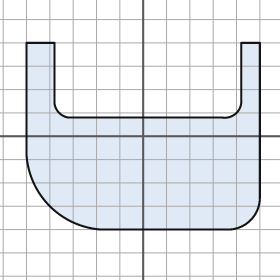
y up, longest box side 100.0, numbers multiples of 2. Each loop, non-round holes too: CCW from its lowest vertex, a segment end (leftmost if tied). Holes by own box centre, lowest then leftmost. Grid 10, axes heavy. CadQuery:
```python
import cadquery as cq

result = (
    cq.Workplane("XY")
    .moveTo(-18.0, -40.0)
    .lineTo(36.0, -40.0)
    .threePointArc((46.0, -36.0), (50.0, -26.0))
    .lineTo(50.0, 40.0)
    .lineTo(42.0, 40.0)
    .lineTo(42.0, 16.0)
    .threePointArc((40.0, 10.0), (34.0, 8.0))
    .lineTo(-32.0, 8.0)
    .threePointArc((-36.0, 10.0), (-38.0, 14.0))
    .lineTo(-38.0, 40.0)
    .lineTo(-50.0, 40.0)
    .lineTo(-50.0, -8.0)
    .threePointArc((-40.0, -30.0), (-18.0, -40.0))
    .close()
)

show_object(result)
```